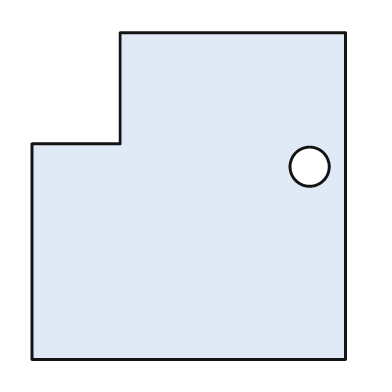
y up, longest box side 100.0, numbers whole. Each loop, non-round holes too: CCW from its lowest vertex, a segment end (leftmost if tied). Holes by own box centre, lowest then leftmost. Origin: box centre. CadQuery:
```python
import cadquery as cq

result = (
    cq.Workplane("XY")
    .moveTo(-48.0, -50.0)
    .lineTo(48.0, -50.0)
    .lineTo(48.0, 50.0)
    .lineTo(-21.0, 50.0)
    .lineTo(-21.0, 16.0)
    .lineTo(-48.0, 16.0)
    .close()
    .moveTo(37.0, 9.0)
    .circle(6.0)
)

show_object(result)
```